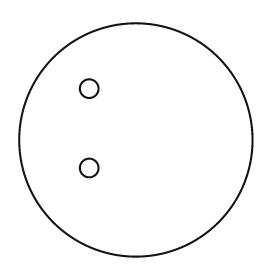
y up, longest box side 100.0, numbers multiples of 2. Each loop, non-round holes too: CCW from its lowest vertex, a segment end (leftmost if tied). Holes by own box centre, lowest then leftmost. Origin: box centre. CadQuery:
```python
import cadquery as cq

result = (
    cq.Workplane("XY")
    .moveTo(0.0, 0.0)
    .circle(50.0)
    .moveTo(-20.0, -12.0)
    .circle(4.0)
    .moveTo(-20.0, 22.0)
    .circle(4.0)
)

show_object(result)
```